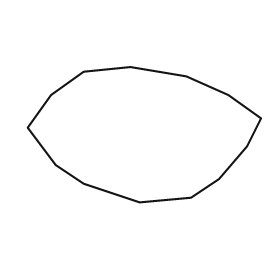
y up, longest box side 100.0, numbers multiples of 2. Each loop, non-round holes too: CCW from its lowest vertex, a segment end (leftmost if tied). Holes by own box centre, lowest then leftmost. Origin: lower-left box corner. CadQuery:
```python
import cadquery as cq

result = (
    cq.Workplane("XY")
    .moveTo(48.0, 0.0)
    .lineTo(70.0, 2.0)
    .lineTo(82.0, 10.0)
    .lineTo(94.0, 24.0)
    .lineTo(100.0, 36.0)
    .lineTo(86.0, 46.0)
    .lineTo(68.0, 54.0)
    .lineTo(44.0, 58.0)
    .lineTo(24.0, 56.0)
    .lineTo(10.0, 46.0)
    .lineTo(0.0, 32.0)
    .lineTo(12.0, 16.0)
    .lineTo(24.0, 8.0)
    .close()
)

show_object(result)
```